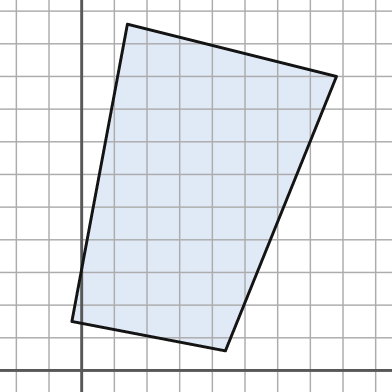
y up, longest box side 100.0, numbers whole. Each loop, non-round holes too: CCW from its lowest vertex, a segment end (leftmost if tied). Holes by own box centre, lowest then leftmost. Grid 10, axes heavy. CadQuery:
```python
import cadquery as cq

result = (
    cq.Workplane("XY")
    .moveTo(44.0, 6.0)
    .lineTo(78.0, 90.0)
    .lineTo(14.0, 106.0)
    .lineTo(-3.0, 15.0)
    .close()
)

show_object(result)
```